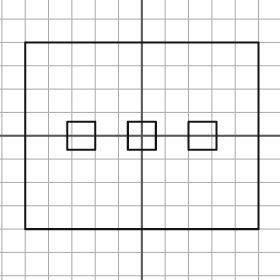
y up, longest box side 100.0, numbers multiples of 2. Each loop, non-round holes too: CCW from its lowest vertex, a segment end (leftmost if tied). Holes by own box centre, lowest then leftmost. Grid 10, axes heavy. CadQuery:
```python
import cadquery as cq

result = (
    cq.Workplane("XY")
    .moveTo(-50.0, -40.0)
    .lineTo(50.0, -40.0)
    .lineTo(50.0, 40.0)
    .lineTo(-50.0, 40.0)
    .close()
    .moveTo(-32.0, -6.0)
    .lineTo(-20.0, -6.0)
    .lineTo(-20.0, 6.0)
    .lineTo(-32.0, 6.0)
    .close()
    .moveTo(-6.0, -6.0)
    .lineTo(6.0, -6.0)
    .lineTo(6.0, 6.0)
    .lineTo(-6.0, 6.0)
    .close()
    .moveTo(20.0, -6.0)
    .lineTo(32.0, -6.0)
    .lineTo(32.0, 6.0)
    .lineTo(20.0, 6.0)
    .close()
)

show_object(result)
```